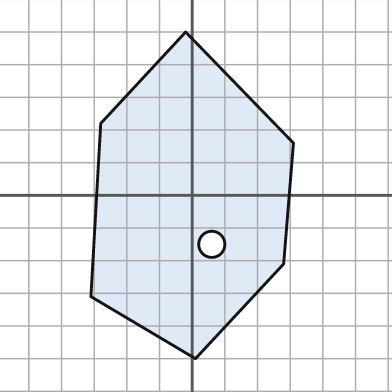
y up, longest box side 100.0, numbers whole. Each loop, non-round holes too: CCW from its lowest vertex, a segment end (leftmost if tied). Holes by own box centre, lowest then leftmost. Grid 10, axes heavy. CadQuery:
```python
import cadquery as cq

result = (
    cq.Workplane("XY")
    .moveTo(1.0, -50.0)
    .lineTo(28.0, -21.0)
    .lineTo(31.0, 16.0)
    .lineTo(-2.0, 50.0)
    .lineTo(-28.0, 22.0)
    .lineTo(-31.0, -31.0)
    .close()
    .moveTo(6.0, -15.0)
    .circle(4.0)
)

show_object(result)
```